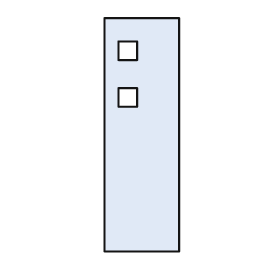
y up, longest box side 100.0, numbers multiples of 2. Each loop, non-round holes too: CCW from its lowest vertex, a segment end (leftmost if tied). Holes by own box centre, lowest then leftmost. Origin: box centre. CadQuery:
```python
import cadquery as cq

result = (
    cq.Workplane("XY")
    .moveTo(-16.0, -50.0)
    .lineTo(16.0, -50.0)
    .lineTo(16.0, 50.0)
    .lineTo(-16.0, 50.0)
    .close()
    .moveTo(-10.0, 12.0)
    .lineTo(-2.0, 12.0)
    .lineTo(-2.0, 20.0)
    .lineTo(-10.0, 20.0)
    .close()
    .moveTo(-10.0, 32.0)
    .lineTo(-2.0, 32.0)
    .lineTo(-2.0, 40.0)
    .lineTo(-10.0, 40.0)
    .close()
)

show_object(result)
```